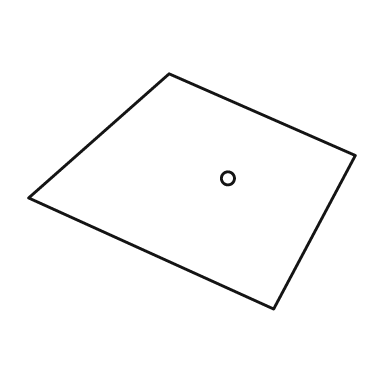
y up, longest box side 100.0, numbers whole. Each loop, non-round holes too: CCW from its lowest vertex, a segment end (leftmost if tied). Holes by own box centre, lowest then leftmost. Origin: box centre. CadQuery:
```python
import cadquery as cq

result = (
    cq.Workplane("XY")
    .moveTo(25.0, -36.0)
    .lineTo(50.0, 11.0)
    .lineTo(-7.0, 36.0)
    .lineTo(-50.0, -2.0)
    .close()
    .moveTo(11.0, 4.0)
    .circle(2.0)
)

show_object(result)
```